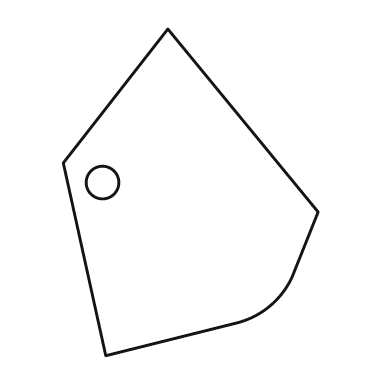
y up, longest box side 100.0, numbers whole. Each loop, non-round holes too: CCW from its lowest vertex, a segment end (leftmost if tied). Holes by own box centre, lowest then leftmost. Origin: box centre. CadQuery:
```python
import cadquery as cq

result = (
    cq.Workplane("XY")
    .moveTo(-26.0, -50.0)
    .lineTo(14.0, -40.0)
    .threePointArc((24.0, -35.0), (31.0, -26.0))
    .lineTo(39.0, -6.0)
    .lineTo(-7.0, 50.0)
    .lineTo(-39.0, 9.0)
    .close()
    .moveTo(-27.0, 3.0)
    .circle(5.0)
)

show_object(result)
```